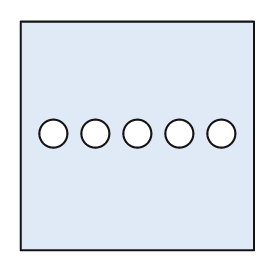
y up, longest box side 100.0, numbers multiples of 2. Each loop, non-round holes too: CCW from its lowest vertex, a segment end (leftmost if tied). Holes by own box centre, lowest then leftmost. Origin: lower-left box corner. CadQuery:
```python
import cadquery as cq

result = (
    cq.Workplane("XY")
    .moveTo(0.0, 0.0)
    .lineTo(100.0, 0.0)
    .lineTo(100.0, 98.0)
    .lineTo(0.0, 98.0)
    .close()
    .moveTo(14.0, 50.0)
    .circle(6.0)
    .moveTo(32.0, 50.0)
    .circle(6.0)
    .moveTo(50.0, 50.0)
    .circle(6.0)
    .moveTo(68.0, 50.0)
    .circle(6.0)
    .moveTo(86.0, 50.0)
    .circle(6.0)
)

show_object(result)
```